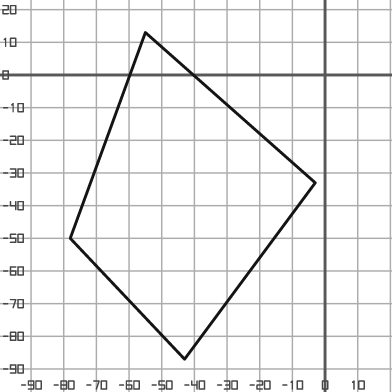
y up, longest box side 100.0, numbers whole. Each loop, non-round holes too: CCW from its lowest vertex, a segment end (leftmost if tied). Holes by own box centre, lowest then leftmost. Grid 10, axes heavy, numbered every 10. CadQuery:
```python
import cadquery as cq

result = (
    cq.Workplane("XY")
    .moveTo(-43.0, -87.0)
    .lineTo(-3.0, -33.0)
    .lineTo(-55.0, 13.0)
    .lineTo(-78.0, -50.0)
    .close()
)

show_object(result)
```